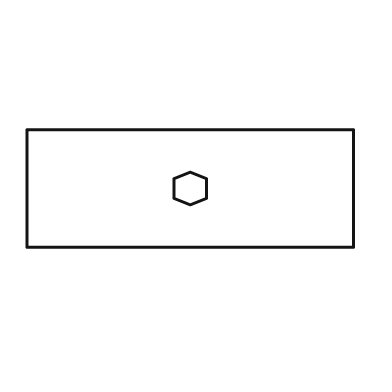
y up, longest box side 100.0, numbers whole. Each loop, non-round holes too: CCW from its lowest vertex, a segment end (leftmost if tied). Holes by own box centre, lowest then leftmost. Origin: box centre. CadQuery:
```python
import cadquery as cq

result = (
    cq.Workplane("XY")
    .moveTo(-50.0, -18.0)
    .lineTo(50.0, -18.0)
    .lineTo(50.0, 18.0)
    .lineTo(-50.0, 18.0)
    .close()
    .moveTo(0.0, -5.0)
    .lineTo(5.0, -3.0)
    .lineTo(5.0, 3.0)
    .lineTo(0.0, 5.0)
    .lineTo(-5.0, 3.0)
    .lineTo(-5.0, -3.0)
    .close()
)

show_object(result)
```